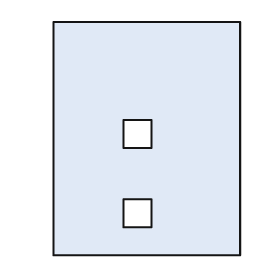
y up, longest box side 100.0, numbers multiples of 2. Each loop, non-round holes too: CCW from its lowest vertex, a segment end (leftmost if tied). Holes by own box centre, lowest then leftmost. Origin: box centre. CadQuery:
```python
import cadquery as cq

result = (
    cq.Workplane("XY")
    .moveTo(-40.0, -50.0)
    .lineTo(40.0, -50.0)
    .lineTo(40.0, 50.0)
    .lineTo(-40.0, 50.0)
    .close()
    .moveTo(-10.0, -38.0)
    .lineTo(2.0, -38.0)
    .lineTo(2.0, -26.0)
    .lineTo(-10.0, -26.0)
    .close()
    .moveTo(-10.0, -4.0)
    .lineTo(2.0, -4.0)
    .lineTo(2.0, 8.0)
    .lineTo(-10.0, 8.0)
    .close()
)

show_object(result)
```